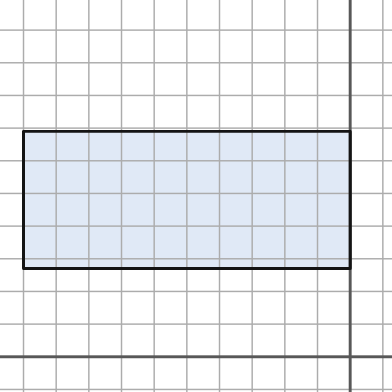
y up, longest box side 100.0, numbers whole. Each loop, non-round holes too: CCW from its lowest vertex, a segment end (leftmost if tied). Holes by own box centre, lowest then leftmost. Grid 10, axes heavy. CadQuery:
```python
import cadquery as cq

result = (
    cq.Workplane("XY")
    .moveTo(-100.0, 27.0)
    .lineTo(0.0, 27.0)
    .lineTo(0.0, 69.0)
    .lineTo(-100.0, 69.0)
    .close()
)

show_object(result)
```